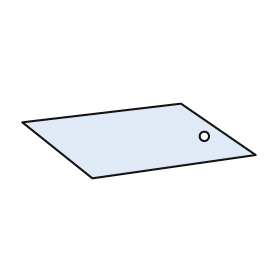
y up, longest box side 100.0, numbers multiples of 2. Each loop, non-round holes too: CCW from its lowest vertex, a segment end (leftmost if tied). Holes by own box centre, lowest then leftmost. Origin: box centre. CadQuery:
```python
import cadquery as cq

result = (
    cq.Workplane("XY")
    .moveTo(-20.0, -16.0)
    .lineTo(50.0, -6.0)
    .lineTo(18.0, 16.0)
    .lineTo(-50.0, 8.0)
    .close()
    .moveTo(28.0, 2.0)
    .circle(2.0)
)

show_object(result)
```